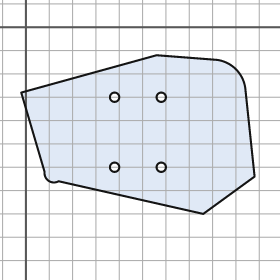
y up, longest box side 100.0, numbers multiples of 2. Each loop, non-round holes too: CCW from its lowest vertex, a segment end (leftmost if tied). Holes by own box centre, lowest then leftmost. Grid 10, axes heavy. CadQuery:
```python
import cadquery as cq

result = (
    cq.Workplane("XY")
    .moveTo(76.0, -80.0)
    .lineTo(98.0, -64.0)
    .lineTo(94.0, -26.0)
    .threePointArc((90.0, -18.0), (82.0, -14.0))
    .lineTo(56.0, -12.0)
    .lineTo(-2.0, -28.0)
    .lineTo(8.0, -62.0)
    .threePointArc((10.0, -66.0), (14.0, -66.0))
    .close()
    .moveTo(38.0, -60.0)
    .circle(2.0)
    .moveTo(58.0, -60.0)
    .circle(2.0)
    .moveTo(38.0, -30.0)
    .circle(2.0)
    .moveTo(58.0, -30.0)
    .circle(2.0)
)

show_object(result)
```